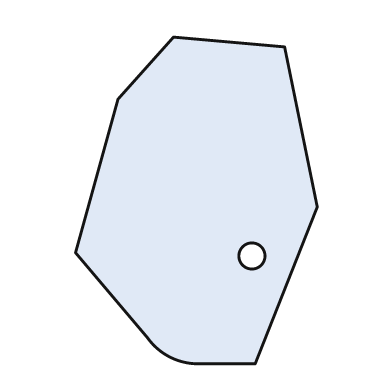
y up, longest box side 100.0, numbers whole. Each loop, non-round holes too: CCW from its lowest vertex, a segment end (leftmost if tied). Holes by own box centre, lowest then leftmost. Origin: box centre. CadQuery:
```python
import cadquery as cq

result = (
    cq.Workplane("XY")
    .moveTo(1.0, -50.0)
    .lineTo(18.0, -50.0)
    .lineTo(37.0, -2.0)
    .lineTo(27.0, 47.0)
    .lineTo(-7.0, 50.0)
    .lineTo(-24.0, 31.0)
    .lineTo(-37.0, -16.0)
    .lineTo(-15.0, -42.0)
    .threePointArc((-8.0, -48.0), (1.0, -50.0))
    .close()
    .moveTo(17.0, -17.0)
    .circle(4.0)
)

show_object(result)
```